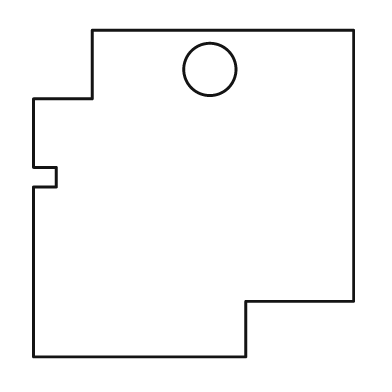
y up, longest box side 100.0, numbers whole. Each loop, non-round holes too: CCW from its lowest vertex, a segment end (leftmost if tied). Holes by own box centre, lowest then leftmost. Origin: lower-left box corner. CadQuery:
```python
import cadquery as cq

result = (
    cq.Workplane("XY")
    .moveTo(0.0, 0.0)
    .lineTo(65.0, 0.0)
    .lineTo(65.0, 17.0)
    .lineTo(98.0, 17.0)
    .lineTo(98.0, 100.0)
    .lineTo(18.0, 100.0)
    .lineTo(18.0, 79.0)
    .lineTo(0.0, 79.0)
    .lineTo(0.0, 58.0)
    .lineTo(7.0, 58.0)
    .lineTo(7.0, 52.0)
    .lineTo(0.0, 52.0)
    .close()
    .moveTo(54.0, 88.0)
    .circle(8.0)
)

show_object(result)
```